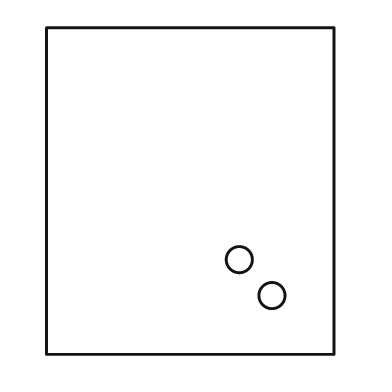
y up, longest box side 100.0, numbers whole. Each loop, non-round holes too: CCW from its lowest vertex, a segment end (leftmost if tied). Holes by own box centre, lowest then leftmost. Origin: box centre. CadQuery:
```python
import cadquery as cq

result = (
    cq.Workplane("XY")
    .moveTo(-44.0, -50.0)
    .lineTo(44.0, -50.0)
    .lineTo(44.0, 50.0)
    .lineTo(-44.0, 50.0)
    .close()
    .moveTo(25.0, -32.0)
    .circle(4.0)
    .moveTo(15.0, -21.0)
    .circle(4.0)
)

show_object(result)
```